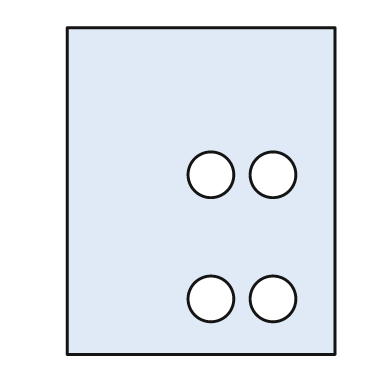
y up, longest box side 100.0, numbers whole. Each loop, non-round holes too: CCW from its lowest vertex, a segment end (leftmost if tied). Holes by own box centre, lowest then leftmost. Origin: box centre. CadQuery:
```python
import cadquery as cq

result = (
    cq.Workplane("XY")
    .moveTo(-41.0, -50.0)
    .lineTo(41.0, -50.0)
    .lineTo(41.0, 50.0)
    .lineTo(-41.0, 50.0)
    .close()
    .moveTo(3.0, -33.0)
    .circle(7.0)
    .moveTo(22.0, -33.0)
    .circle(7.0)
    .moveTo(3.0, 5.0)
    .circle(7.0)
    .moveTo(22.0, 5.0)
    .circle(7.0)
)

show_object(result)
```